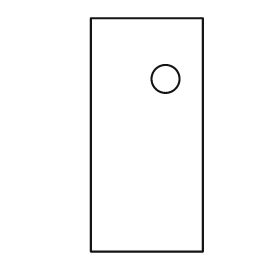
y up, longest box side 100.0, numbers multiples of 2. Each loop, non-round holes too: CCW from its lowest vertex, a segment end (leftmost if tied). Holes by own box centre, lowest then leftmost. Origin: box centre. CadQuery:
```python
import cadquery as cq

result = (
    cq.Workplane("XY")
    .moveTo(-24.0, -50.0)
    .lineTo(24.0, -50.0)
    .lineTo(24.0, 50.0)
    .lineTo(-24.0, 50.0)
    .close()
    .moveTo(8.0, 24.0)
    .circle(6.0)
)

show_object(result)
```